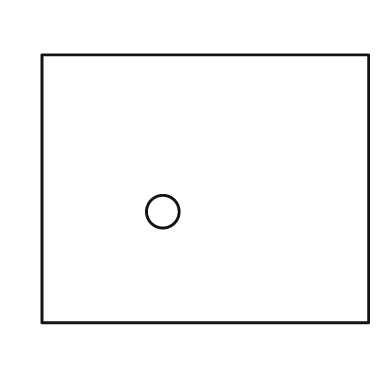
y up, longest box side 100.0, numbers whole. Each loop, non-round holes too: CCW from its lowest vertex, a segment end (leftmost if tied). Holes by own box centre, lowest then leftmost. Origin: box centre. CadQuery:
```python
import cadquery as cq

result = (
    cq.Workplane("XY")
    .moveTo(-50.0, -41.0)
    .lineTo(50.0, -41.0)
    .lineTo(50.0, 41.0)
    .lineTo(-50.0, 41.0)
    .close()
    .moveTo(-13.0, -7.0)
    .circle(5.0)
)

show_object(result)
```